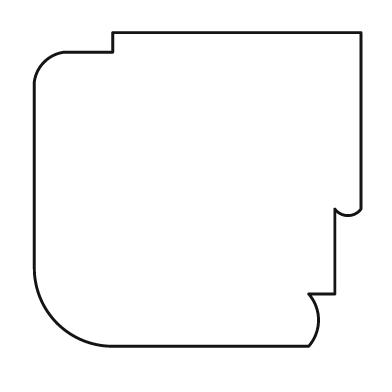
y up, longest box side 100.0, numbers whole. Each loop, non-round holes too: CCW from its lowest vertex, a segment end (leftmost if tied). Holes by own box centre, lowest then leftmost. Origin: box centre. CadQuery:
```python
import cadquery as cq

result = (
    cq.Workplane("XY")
    .moveTo(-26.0, -48.0)
    .lineTo(34.0, -48.0)
    .threePointArc((37.0, -40.0), (34.0, -32.0))
    .lineTo(42.0, -32.0)
    .lineTo(42.0, -6.0)
    .threePointArc((46.0, -8.0), (50.0, -6.0))
    .lineTo(50.0, 48.0)
    .lineTo(-26.0, 48.0)
    .lineTo(-26.0, 42.0)
    .lineTo(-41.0, 42.0)
    .threePointArc((-47.0, 39.0), (-50.0, 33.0))
    .lineTo(-50.0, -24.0)
    .threePointArc((-43.0, -41.0), (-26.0, -48.0))
    .close()
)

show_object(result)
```